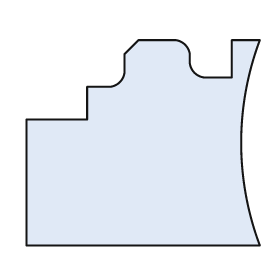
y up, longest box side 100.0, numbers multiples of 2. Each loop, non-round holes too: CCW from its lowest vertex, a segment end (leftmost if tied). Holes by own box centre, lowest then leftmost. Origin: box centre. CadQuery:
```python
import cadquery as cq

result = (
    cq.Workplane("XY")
    .moveTo(-50.0, -44.0)
    .lineTo(50.0, -44.0)
    .threePointArc((42.0, 0.0), (50.0, 44.0))
    .lineTo(38.0, 44.0)
    .lineTo(38.0, 28.0)
    .lineTo(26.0, 28.0)
    .threePointArc((22.0, 30.0), (20.0, 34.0))
    .lineTo(20.0, 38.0)
    .threePointArc((18.0, 42.0), (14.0, 44.0))
    .lineTo(-2.0, 44.0)
    .lineTo(-8.0, 38.0)
    .lineTo(-8.0, 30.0)
    .threePointArc((-10.0, 26.0), (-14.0, 24.0))
    .lineTo(-24.0, 24.0)
    .lineTo(-24.0, 10.0)
    .lineTo(-50.0, 10.0)
    .close()
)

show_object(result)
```